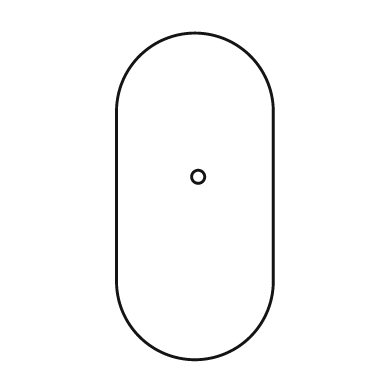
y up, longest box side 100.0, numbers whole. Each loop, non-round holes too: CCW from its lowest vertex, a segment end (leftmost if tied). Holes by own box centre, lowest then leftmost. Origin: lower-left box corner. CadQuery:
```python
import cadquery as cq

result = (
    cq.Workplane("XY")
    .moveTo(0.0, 24.0)
    .threePointArc((24.0, 0.0), (48.0, 24.0))
    .lineTo(48.0, 76.0)
    .threePointArc((24.0, 100.0), (0.0, 76.0))
    .close()
    .moveTo(25.0, 56.0)
    .circle(2.0)
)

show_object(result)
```